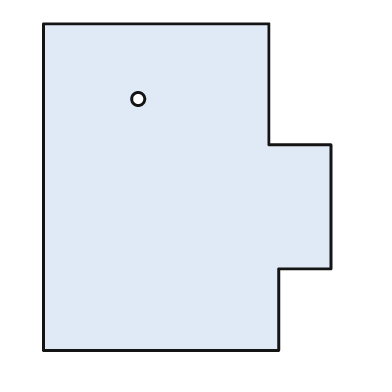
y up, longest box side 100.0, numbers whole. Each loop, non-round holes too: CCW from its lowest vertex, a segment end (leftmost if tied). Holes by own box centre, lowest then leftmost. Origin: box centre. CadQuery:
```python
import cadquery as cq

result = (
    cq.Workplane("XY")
    .moveTo(-44.0, -50.0)
    .lineTo(28.0, -50.0)
    .lineTo(28.0, -25.0)
    .lineTo(44.0, -25.0)
    .lineTo(44.0, 13.0)
    .lineTo(25.0, 13.0)
    .lineTo(25.0, 50.0)
    .lineTo(-44.0, 50.0)
    .close()
    .moveTo(-15.0, 27.0)
    .circle(2.0)
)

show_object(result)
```